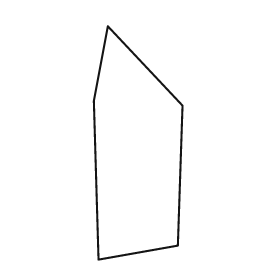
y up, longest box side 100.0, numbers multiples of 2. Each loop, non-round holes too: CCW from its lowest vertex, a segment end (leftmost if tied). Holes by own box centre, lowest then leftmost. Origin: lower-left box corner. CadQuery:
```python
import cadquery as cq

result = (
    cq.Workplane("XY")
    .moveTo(2.0, 0.0)
    .lineTo(36.0, 6.0)
    .lineTo(38.0, 66.0)
    .lineTo(6.0, 100.0)
    .lineTo(0.0, 68.0)
    .close()
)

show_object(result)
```